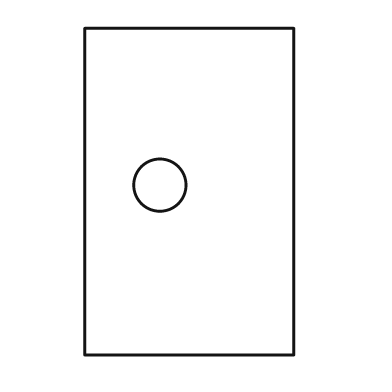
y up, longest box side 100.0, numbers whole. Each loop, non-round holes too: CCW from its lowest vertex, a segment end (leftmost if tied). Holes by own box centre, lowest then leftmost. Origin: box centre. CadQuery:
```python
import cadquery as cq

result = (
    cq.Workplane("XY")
    .moveTo(-32.0, -50.0)
    .lineTo(32.0, -50.0)
    .lineTo(32.0, 50.0)
    .lineTo(-32.0, 50.0)
    .close()
    .moveTo(-9.0, 2.0)
    .circle(8.0)
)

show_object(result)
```